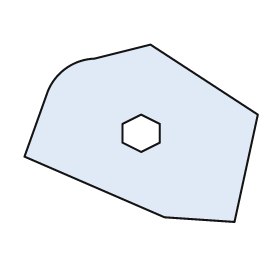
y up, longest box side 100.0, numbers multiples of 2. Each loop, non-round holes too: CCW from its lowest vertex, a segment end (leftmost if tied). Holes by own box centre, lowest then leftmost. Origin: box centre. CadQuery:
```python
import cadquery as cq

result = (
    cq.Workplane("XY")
    .moveTo(40.0, -38.0)
    .lineTo(50.0, 8.0)
    .lineTo(4.0, 38.0)
    .lineTo(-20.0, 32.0)
    .threePointArc((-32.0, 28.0), (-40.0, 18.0))
    .lineTo(-50.0, -10.0)
    .lineTo(10.0, -36.0)
    .close()
    .moveTo(0.0, -8.0)
    .lineTo(8.0, -4.0)
    .lineTo(8.0, 4.0)
    .lineTo(0.0, 8.0)
    .lineTo(-8.0, 4.0)
    .lineTo(-8.0, -4.0)
    .close()
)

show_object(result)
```